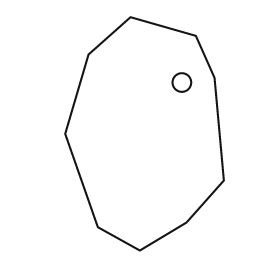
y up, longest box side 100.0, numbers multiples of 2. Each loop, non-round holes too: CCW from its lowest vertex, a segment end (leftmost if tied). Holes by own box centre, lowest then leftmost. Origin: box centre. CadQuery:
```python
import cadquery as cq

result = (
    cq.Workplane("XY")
    .moveTo(-2.0, -50.0)
    .lineTo(18.0, -38.0)
    .lineTo(34.0, -20.0)
    .lineTo(30.0, 24.0)
    .lineTo(22.0, 42.0)
    .lineTo(-6.0, 50.0)
    .lineTo(-24.0, 34.0)
    .lineTo(-34.0, 0.0)
    .lineTo(-20.0, -40.0)
    .close()
    .moveTo(16.0, 22.0)
    .circle(4.0)
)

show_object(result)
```